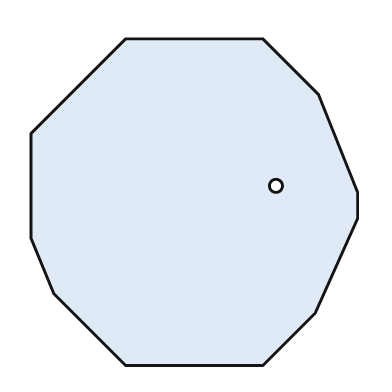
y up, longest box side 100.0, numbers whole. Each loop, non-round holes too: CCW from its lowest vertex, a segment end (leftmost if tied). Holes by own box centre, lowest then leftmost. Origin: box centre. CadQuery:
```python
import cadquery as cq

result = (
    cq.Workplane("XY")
    .moveTo(-21.0, -50.0)
    .lineTo(21.0, -50.0)
    .lineTo(37.0, -34.0)
    .lineTo(50.0, -5.0)
    .lineTo(50.0, 3.0)
    .lineTo(38.0, 33.0)
    .lineTo(21.0, 50.0)
    .lineTo(-21.0, 50.0)
    .lineTo(-50.0, 21.0)
    .lineTo(-50.0, -11.0)
    .lineTo(-43.0, -28.0)
    .close()
    .moveTo(25.0, 5.0)
    .circle(2.0)
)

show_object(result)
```